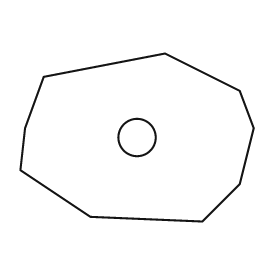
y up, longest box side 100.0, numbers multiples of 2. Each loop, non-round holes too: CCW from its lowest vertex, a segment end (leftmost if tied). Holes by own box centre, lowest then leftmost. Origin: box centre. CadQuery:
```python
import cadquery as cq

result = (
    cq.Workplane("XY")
    .moveTo(28.0, -36.0)
    .lineTo(44.0, -20.0)
    .lineTo(50.0, 4.0)
    .lineTo(44.0, 20.0)
    .lineTo(12.0, 36.0)
    .lineTo(-40.0, 26.0)
    .lineTo(-48.0, 4.0)
    .lineTo(-50.0, -14.0)
    .lineTo(-20.0, -34.0)
    .close()
    .moveTo(0.0, 0.0)
    .circle(8.0)
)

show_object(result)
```